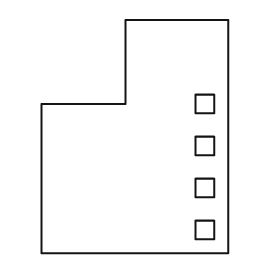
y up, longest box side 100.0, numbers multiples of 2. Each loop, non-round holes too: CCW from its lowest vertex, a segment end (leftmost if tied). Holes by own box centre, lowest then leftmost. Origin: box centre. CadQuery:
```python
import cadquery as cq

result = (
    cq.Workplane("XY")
    .moveTo(-40.0, -50.0)
    .lineTo(40.0, -50.0)
    .lineTo(40.0, 50.0)
    .lineTo(-4.0, 50.0)
    .lineTo(-4.0, 14.0)
    .lineTo(-40.0, 14.0)
    .close()
    .moveTo(26.0, -44.0)
    .lineTo(34.0, -44.0)
    .lineTo(34.0, -36.0)
    .lineTo(26.0, -36.0)
    .close()
    .moveTo(26.0, -26.0)
    .lineTo(34.0, -26.0)
    .lineTo(34.0, -18.0)
    .lineTo(26.0, -18.0)
    .close()
    .moveTo(26.0, -8.0)
    .lineTo(34.0, -8.0)
    .lineTo(34.0, 0.0)
    .lineTo(26.0, 0.0)
    .close()
    .moveTo(26.0, 10.0)
    .lineTo(34.0, 10.0)
    .lineTo(34.0, 18.0)
    .lineTo(26.0, 18.0)
    .close()
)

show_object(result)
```